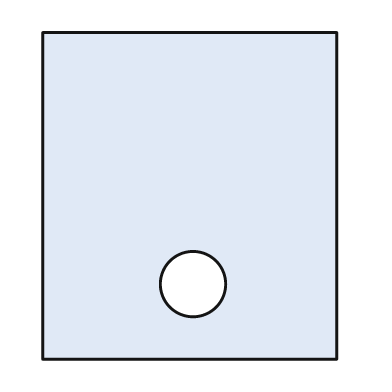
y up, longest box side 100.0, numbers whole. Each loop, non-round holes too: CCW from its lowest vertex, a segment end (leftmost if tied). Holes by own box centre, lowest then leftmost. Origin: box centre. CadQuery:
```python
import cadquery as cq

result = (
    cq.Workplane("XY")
    .moveTo(-45.0, -50.0)
    .lineTo(45.0, -50.0)
    .lineTo(45.0, 50.0)
    .lineTo(-45.0, 50.0)
    .close()
    .moveTo(1.0, -27.0)
    .circle(10.0)
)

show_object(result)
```